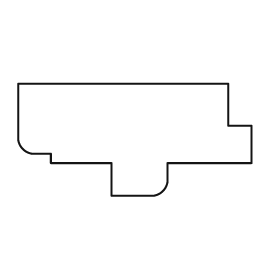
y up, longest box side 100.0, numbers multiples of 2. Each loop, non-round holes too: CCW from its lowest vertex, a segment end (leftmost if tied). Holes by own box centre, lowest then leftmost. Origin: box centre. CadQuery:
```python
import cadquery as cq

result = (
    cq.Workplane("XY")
    .moveTo(-10.0, -24.0)
    .lineTo(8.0, -24.0)
    .threePointArc((12.0, -22.0), (14.0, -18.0))
    .lineTo(14.0, -10.0)
    .lineTo(50.0, -10.0)
    .lineTo(50.0, 6.0)
    .lineTo(40.0, 6.0)
    .lineTo(40.0, 24.0)
    .lineTo(-50.0, 24.0)
    .lineTo(-50.0, 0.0)
    .threePointArc((-48.0, -4.0), (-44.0, -6.0))
    .lineTo(-36.0, -6.0)
    .lineTo(-36.0, -10.0)
    .lineTo(-10.0, -10.0)
    .close()
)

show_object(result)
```